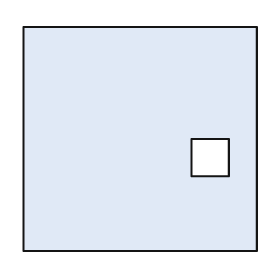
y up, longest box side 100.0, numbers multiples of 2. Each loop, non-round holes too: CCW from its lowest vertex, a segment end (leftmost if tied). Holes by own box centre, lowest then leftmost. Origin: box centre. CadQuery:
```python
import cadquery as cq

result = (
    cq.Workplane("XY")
    .moveTo(-50.0, -48.0)
    .lineTo(50.0, -48.0)
    .lineTo(50.0, 48.0)
    .lineTo(-50.0, 48.0)
    .close()
    .moveTo(22.0, -16.0)
    .lineTo(38.0, -16.0)
    .lineTo(38.0, 0.0)
    .lineTo(22.0, 0.0)
    .close()
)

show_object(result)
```